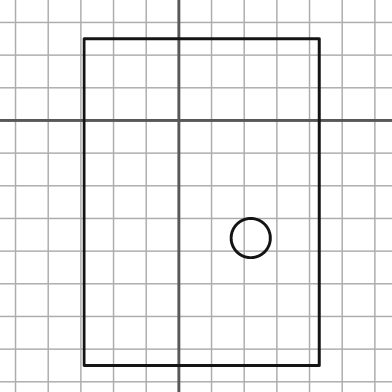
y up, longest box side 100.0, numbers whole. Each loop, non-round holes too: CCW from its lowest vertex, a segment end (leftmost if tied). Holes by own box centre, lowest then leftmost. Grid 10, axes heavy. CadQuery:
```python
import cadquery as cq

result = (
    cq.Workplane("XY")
    .moveTo(-29.0, -75.0)
    .lineTo(43.0, -75.0)
    .lineTo(43.0, 25.0)
    .lineTo(-29.0, 25.0)
    .close()
    .moveTo(22.0, -36.0)
    .circle(6.0)
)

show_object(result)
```